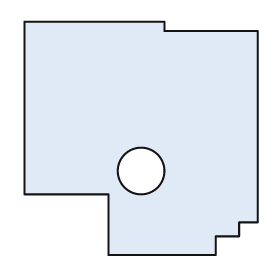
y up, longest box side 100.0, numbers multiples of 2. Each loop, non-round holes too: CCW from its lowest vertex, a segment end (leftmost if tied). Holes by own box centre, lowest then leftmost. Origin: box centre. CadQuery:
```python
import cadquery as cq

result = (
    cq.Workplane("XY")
    .moveTo(-14.0, -50.0)
    .lineTo(32.0, -50.0)
    .lineTo(32.0, -42.0)
    .lineTo(42.0, -42.0)
    .lineTo(42.0, -36.0)
    .lineTo(50.0, -36.0)
    .lineTo(50.0, 46.0)
    .lineTo(10.0, 46.0)
    .lineTo(10.0, 50.0)
    .lineTo(-50.0, 50.0)
    .lineTo(-50.0, -24.0)
    .lineTo(-14.0, -24.0)
    .close()
    .moveTo(0.0, -14.0)
    .circle(10.0)
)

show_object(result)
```